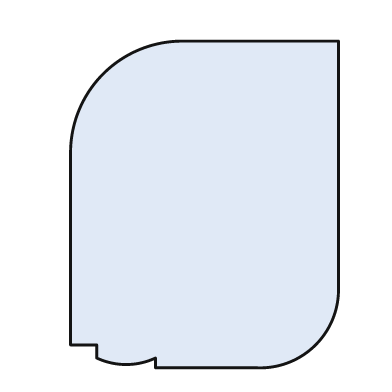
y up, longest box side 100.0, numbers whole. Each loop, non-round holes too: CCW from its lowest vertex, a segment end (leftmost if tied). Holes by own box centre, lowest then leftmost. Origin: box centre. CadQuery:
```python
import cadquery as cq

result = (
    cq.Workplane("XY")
    .moveTo(-15.0, -50.0)
    .lineTo(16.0, -50.0)
    .threePointArc((34.0, -43.0), (41.0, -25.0))
    .lineTo(41.0, 50.0)
    .lineTo(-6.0, 50.0)
    .threePointArc((-31.0, 40.0), (-41.0, 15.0))
    .lineTo(-41.0, -43.0)
    .lineTo(-33.0, -43.0)
    .lineTo(-33.0, -47.0)
    .threePointArc((-24.0, -49.0), (-15.0, -47.0))
    .close()
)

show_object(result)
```